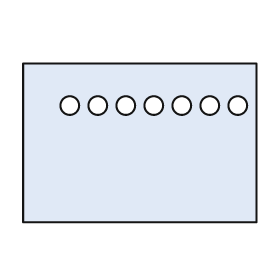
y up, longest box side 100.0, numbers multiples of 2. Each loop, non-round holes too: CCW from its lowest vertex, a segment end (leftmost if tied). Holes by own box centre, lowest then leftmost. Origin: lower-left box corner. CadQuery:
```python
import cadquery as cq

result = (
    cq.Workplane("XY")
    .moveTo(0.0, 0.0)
    .lineTo(100.0, 0.0)
    .lineTo(100.0, 68.0)
    .lineTo(0.0, 68.0)
    .close()
    .moveTo(20.0, 50.0)
    .circle(4.0)
    .moveTo(32.0, 50.0)
    .circle(4.0)
    .moveTo(44.0, 50.0)
    .circle(4.0)
    .moveTo(56.0, 50.0)
    .circle(4.0)
    .moveTo(68.0, 50.0)
    .circle(4.0)
    .moveTo(80.0, 50.0)
    .circle(4.0)
    .moveTo(92.0, 50.0)
    .circle(4.0)
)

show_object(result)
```